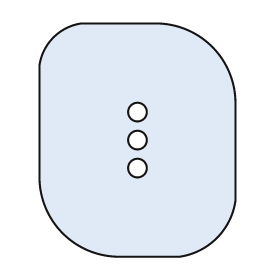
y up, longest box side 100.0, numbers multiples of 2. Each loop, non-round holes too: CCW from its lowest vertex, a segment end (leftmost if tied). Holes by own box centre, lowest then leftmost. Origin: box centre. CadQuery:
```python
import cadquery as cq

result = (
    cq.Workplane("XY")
    .moveTo(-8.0, -50.0)
    .lineTo(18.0, -50.0)
    .threePointArc((34.0, -42.0), (42.0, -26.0))
    .lineTo(42.0, 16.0)
    .threePointArc((32.0, 40.0), (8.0, 50.0))
    .lineTo(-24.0, 50.0)
    .threePointArc((-36.0, 44.0), (-42.0, 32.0))
    .lineTo(-42.0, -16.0)
    .threePointArc((-32.0, -40.0), (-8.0, -50.0))
    .close()
    .moveTo(0.0, -12.0)
    .circle(4.0)
    .moveTo(0.0, 0.0)
    .circle(4.0)
    .moveTo(0.0, 12.0)
    .circle(4.0)
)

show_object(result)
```